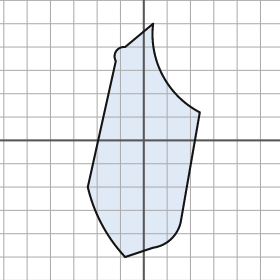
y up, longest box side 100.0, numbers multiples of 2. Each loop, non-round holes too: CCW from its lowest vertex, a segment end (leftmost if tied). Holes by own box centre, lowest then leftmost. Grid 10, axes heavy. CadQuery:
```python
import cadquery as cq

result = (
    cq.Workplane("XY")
    .moveTo(-8.0, -50.0)
    .lineTo(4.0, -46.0)
    .threePointArc((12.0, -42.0), (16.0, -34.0))
    .lineTo(24.0, 12.0)
    .threePointArc((8.0, 28.0), (4.0, 50.0))
    .lineTo(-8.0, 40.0)
    .threePointArc((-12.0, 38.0), (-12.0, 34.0))
    .lineTo(-24.0, -20.0)
    .threePointArc((-18.0, -36.0), (-8.0, -50.0))
    .close()
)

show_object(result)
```